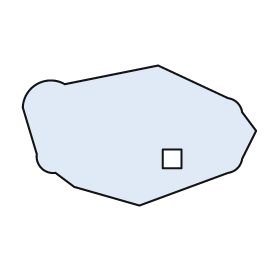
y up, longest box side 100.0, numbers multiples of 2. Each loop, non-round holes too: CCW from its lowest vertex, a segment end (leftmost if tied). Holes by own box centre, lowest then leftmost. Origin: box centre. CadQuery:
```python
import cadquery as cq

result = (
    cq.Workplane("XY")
    .moveTo(0.0, -30.0)
    .lineTo(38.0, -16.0)
    .threePointArc((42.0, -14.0), (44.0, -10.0))
    .lineTo(50.0, 2.0)
    .lineTo(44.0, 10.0)
    .threePointArc((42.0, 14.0), (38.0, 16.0))
    .lineTo(8.0, 30.0)
    .lineTo(-32.0, 22.0)
    .threePointArc((-44.0, 22.0), (-50.0, 12.0))
    .lineTo(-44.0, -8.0)
    .threePointArc((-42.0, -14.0), (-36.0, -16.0))
    .lineTo(-28.0, -22.0)
    .close()
    .moveTo(10.0, -14.0)
    .lineTo(18.0, -14.0)
    .lineTo(18.0, -6.0)
    .lineTo(10.0, -6.0)
    .close()
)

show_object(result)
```